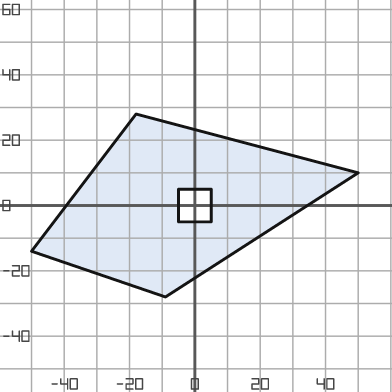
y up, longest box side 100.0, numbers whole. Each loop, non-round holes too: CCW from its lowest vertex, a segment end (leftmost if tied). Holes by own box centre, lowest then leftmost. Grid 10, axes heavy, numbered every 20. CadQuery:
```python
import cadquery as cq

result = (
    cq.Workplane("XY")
    .moveTo(-9.0, -28.0)
    .lineTo(50.0, 10.0)
    .lineTo(-18.0, 28.0)
    .lineTo(-50.0, -14.0)
    .close()
    .moveTo(-5.0, -5.0)
    .lineTo(5.0, -5.0)
    .lineTo(5.0, 5.0)
    .lineTo(-5.0, 5.0)
    .close()
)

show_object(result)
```